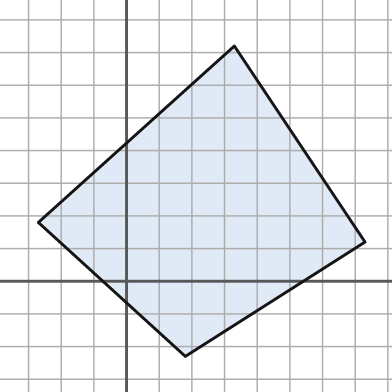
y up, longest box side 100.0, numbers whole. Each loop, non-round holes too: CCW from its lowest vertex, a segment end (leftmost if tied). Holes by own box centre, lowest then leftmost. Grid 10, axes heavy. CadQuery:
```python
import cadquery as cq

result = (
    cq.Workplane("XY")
    .moveTo(18.0, -23.0)
    .lineTo(73.0, 12.0)
    .lineTo(33.0, 72.0)
    .lineTo(-27.0, 18.0)
    .close()
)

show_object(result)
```